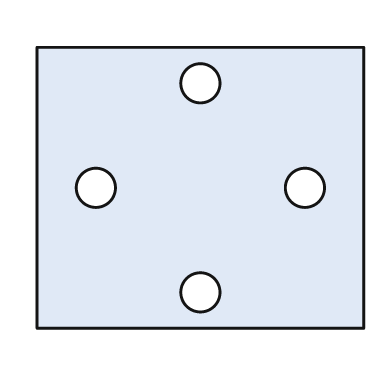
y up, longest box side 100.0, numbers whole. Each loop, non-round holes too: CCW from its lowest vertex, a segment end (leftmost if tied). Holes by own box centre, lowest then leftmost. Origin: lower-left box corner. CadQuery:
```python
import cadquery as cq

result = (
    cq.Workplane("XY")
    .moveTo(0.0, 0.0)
    .lineTo(100.0, 0.0)
    .lineTo(100.0, 86.0)
    .lineTo(0.0, 86.0)
    .close()
    .moveTo(50.0, 11.0)
    .circle(6.0)
    .moveTo(18.0, 43.0)
    .circle(6.0)
    .moveTo(82.0, 43.0)
    .circle(6.0)
    .moveTo(50.0, 75.0)
    .circle(6.0)
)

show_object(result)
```